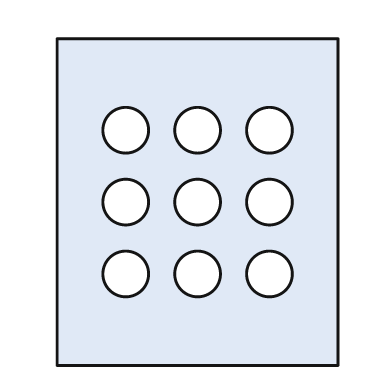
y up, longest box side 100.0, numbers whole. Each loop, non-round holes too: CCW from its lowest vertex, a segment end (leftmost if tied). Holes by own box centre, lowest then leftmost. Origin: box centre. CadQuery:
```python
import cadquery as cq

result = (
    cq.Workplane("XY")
    .moveTo(-43.0, -50.0)
    .lineTo(43.0, -50.0)
    .lineTo(43.0, 50.0)
    .lineTo(-43.0, 50.0)
    .close()
    .moveTo(-22.0, -22.0)
    .circle(7.0)
    .moveTo(0.0, -22.0)
    .circle(7.0)
    .moveTo(22.0, -22.0)
    .circle(7.0)
    .moveTo(-22.0, 0.0)
    .circle(7.0)
    .moveTo(0.0, 0.0)
    .circle(7.0)
    .moveTo(22.0, 0.0)
    .circle(7.0)
    .moveTo(-22.0, 22.0)
    .circle(7.0)
    .moveTo(0.0, 22.0)
    .circle(7.0)
    .moveTo(22.0, 22.0)
    .circle(7.0)
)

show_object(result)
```